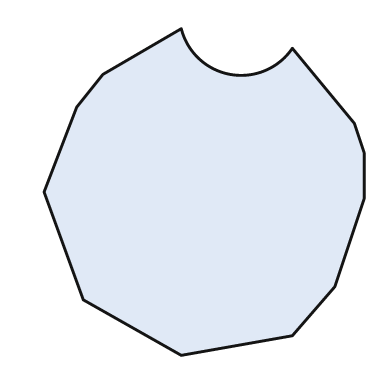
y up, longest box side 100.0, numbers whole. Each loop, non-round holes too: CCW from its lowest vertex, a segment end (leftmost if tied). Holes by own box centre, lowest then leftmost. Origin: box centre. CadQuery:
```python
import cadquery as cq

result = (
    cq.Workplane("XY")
    .moveTo(-7.0, -50.0)
    .lineTo(27.0, -44.0)
    .lineTo(40.0, -29.0)
    .lineTo(49.0, -2.0)
    .lineTo(49.0, 12.0)
    .lineTo(46.0, 21.0)
    .lineTo(27.0, 44.0)
    .threePointArc((8.0, 36.0), (-7.0, 50.0))
    .lineTo(-31.0, 36.0)
    .lineTo(-39.0, 26.0)
    .lineTo(-49.0, 0.0)
    .lineTo(-37.0, -33.0)
    .close()
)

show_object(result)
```